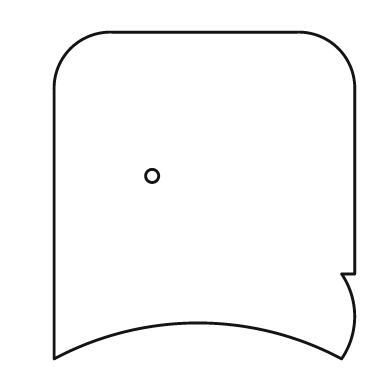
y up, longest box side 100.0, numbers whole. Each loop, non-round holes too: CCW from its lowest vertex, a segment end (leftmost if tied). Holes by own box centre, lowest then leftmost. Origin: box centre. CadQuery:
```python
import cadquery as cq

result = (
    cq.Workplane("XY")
    .moveTo(-46.0, -50.0)
    .threePointArc((-2.0, -39.0), (42.0, -50.0))
    .threePointArc((46.0, -37.0), (42.0, -24.0))
    .lineTo(46.0, -24.0)
    .lineTo(46.0, 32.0)
    .threePointArc((41.0, 45.0), (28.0, 50.0))
    .lineTo(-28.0, 50.0)
    .threePointArc((-41.0, 45.0), (-46.0, 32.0))
    .close()
    .moveTo(-16.0, 6.0)
    .circle(2.0)
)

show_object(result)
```